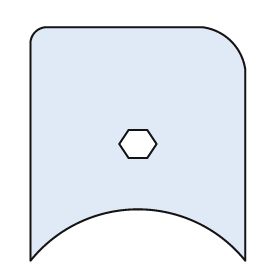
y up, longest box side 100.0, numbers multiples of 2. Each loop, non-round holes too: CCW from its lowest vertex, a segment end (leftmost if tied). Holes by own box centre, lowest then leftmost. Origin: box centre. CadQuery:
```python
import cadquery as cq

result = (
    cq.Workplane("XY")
    .moveTo(-46.0, -50.0)
    .threePointArc((0.0, -28.0), (46.0, -50.0))
    .lineTo(46.0, 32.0)
    .threePointArc((40.0, 44.0), (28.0, 50.0))
    .lineTo(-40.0, 50.0)
    .threePointArc((-44.0, 48.0), (-46.0, 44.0))
    .close()
    .moveTo(-4.0, -6.0)
    .lineTo(4.0, -6.0)
    .lineTo(8.0, 0.0)
    .lineTo(4.0, 6.0)
    .lineTo(-4.0, 6.0)
    .lineTo(-8.0, 0.0)
    .close()
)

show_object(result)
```